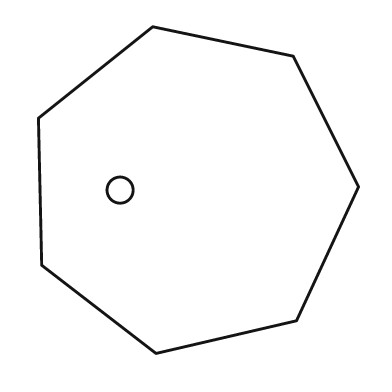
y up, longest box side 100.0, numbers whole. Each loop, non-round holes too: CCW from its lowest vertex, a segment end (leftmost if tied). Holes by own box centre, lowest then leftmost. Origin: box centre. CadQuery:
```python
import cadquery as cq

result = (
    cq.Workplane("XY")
    .moveTo(-13.0, -50.0)
    .lineTo(30.0, -40.0)
    .lineTo(49.0, 1.0)
    .lineTo(29.0, 41.0)
    .lineTo(-14.0, 50.0)
    .lineTo(-49.0, 22.0)
    .lineTo(-48.0, -23.0)
    .close()
    .moveTo(-24.0, 0.0)
    .circle(4.0)
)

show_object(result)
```